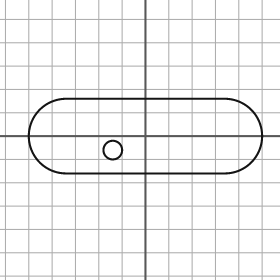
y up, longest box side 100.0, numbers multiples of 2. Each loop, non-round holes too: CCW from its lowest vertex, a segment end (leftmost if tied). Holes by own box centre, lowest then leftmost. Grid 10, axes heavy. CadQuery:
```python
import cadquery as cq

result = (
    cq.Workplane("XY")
    .moveTo(-34.0, -16.0)
    .lineTo(34.0, -16.0)
    .threePointArc((50.0, 0.0), (34.0, 16.0))
    .lineTo(-34.0, 16.0)
    .threePointArc((-50.0, 0.0), (-34.0, -16.0))
    .close()
    .moveTo(-14.0, -6.0)
    .circle(4.0)
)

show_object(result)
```